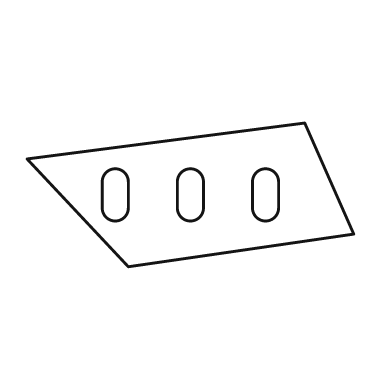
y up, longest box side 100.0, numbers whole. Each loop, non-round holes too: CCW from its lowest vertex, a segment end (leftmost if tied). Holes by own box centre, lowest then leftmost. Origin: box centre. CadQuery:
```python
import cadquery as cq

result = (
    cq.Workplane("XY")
    .moveTo(-19.0, -22.0)
    .lineTo(50.0, -12.0)
    .lineTo(35.0, 22.0)
    .lineTo(-50.0, 11.0)
    .close()
    .moveTo(-27.0, -4.0)
    .threePointArc((-23.0, -8.0), (-19.0, -4.0))
    .lineTo(-19.0, 4.0)
    .threePointArc((-23.0, 8.0), (-27.0, 4.0))
    .close()
    .moveTo(-4.0, -4.0)
    .threePointArc((0.0, -8.0), (4.0, -4.0))
    .lineTo(4.0, 4.0)
    .threePointArc((0.0, 8.0), (-4.0, 4.0))
    .close()
    .moveTo(19.0, -4.0)
    .threePointArc((23.0, -8.0), (27.0, -4.0))
    .lineTo(27.0, 4.0)
    .threePointArc((23.0, 8.0), (19.0, 4.0))
    .close()
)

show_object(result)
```